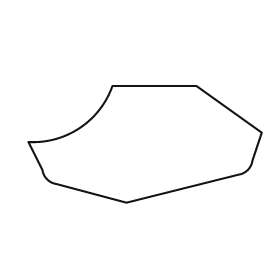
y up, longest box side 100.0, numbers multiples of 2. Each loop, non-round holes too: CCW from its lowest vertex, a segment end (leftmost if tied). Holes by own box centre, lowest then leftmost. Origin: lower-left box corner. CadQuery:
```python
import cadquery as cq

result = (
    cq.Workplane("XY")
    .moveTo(42.0, 0.0)
    .lineTo(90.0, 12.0)
    .threePointArc((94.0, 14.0), (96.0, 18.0))
    .lineTo(100.0, 30.0)
    .lineTo(72.0, 50.0)
    .lineTo(36.0, 50.0)
    .threePointArc((22.0, 32.0), (0.0, 26.0))
    .lineTo(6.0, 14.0)
    .threePointArc((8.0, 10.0), (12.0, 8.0))
    .close()
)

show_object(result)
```